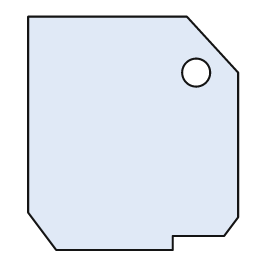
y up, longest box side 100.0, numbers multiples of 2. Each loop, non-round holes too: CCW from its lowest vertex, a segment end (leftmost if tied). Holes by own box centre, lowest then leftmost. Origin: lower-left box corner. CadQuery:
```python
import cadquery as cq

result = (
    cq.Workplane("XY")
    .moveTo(12.0, 0.0)
    .lineTo(62.0, 0.0)
    .lineTo(62.0, 6.0)
    .lineTo(84.0, 6.0)
    .lineTo(90.0, 14.0)
    .lineTo(90.0, 76.0)
    .lineTo(68.0, 100.0)
    .lineTo(0.0, 100.0)
    .lineTo(0.0, 16.0)
    .close()
    .moveTo(72.0, 76.0)
    .circle(6.0)
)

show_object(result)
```